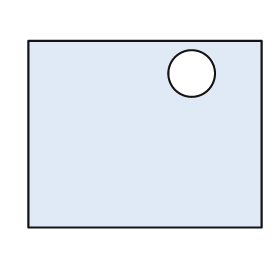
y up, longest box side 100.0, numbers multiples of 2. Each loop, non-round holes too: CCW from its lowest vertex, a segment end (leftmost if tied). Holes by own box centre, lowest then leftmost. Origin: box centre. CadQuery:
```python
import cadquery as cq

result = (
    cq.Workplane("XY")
    .moveTo(-50.0, -40.0)
    .lineTo(50.0, -40.0)
    .lineTo(50.0, 40.0)
    .lineTo(-50.0, 40.0)
    .close()
    .moveTo(20.0, 26.0)
    .circle(10.0)
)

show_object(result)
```